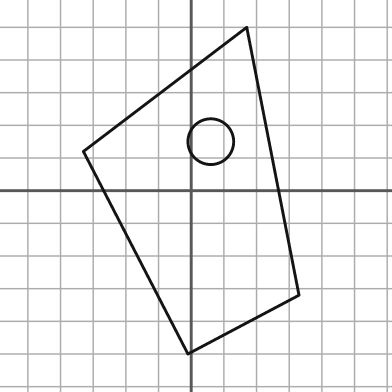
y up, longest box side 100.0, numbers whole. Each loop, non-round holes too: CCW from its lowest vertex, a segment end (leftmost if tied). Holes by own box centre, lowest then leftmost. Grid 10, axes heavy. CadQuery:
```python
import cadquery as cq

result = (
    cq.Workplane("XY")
    .moveTo(-1.0, -50.0)
    .lineTo(33.0, -32.0)
    .lineTo(17.0, 50.0)
    .lineTo(-33.0, 12.0)
    .close()
    .moveTo(6.0, 15.0)
    .circle(7.0)
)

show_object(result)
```